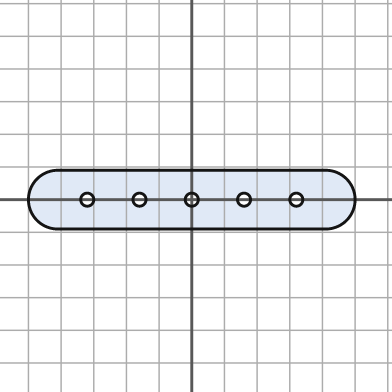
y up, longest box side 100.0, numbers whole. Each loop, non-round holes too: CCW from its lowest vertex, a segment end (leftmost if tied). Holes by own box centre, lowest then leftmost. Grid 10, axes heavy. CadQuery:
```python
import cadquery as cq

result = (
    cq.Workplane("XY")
    .moveTo(-41.0, -9.0)
    .lineTo(41.0, -9.0)
    .threePointArc((50.0, 0.0), (41.0, 9.0))
    .lineTo(-41.0, 9.0)
    .threePointArc((-50.0, 0.0), (-41.0, -9.0))
    .close()
    .moveTo(-32.0, 0.0)
    .circle(2.0)
    .moveTo(-16.0, 0.0)
    .circle(2.0)
    .moveTo(0.0, 0.0)
    .circle(2.0)
    .moveTo(16.0, 0.0)
    .circle(2.0)
    .moveTo(32.0, 0.0)
    .circle(2.0)
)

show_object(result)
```